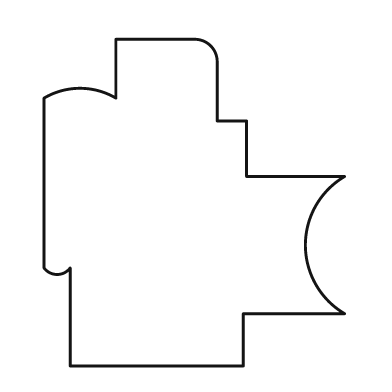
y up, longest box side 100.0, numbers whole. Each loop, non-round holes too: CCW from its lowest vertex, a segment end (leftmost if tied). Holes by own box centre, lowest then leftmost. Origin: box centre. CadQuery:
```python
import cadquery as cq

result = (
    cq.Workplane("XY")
    .moveTo(-38.0, -50.0)
    .lineTo(15.0, -50.0)
    .lineTo(15.0, -34.0)
    .lineTo(46.0, -34.0)
    .threePointArc((34.0, -13.0), (46.0, 8.0))
    .lineTo(16.0, 8.0)
    .lineTo(16.0, 25.0)
    .lineTo(7.0, 25.0)
    .lineTo(7.0, 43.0)
    .threePointArc((5.0, 48.0), (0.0, 50.0))
    .lineTo(-24.0, 50.0)
    .lineTo(-24.0, 32.0)
    .threePointArc((-35.0, 35.0), (-46.0, 32.0))
    .lineTo(-46.0, -20.0)
    .threePointArc((-42.0, -22.0), (-38.0, -20.0))
    .close()
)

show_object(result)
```